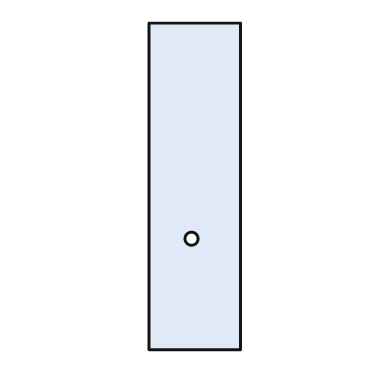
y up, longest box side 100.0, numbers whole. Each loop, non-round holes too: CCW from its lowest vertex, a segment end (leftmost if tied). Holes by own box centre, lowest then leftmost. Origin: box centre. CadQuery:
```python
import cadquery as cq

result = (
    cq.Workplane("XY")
    .moveTo(-14.0, -50.0)
    .lineTo(14.0, -50.0)
    .lineTo(14.0, 50.0)
    .lineTo(-14.0, 50.0)
    .close()
    .moveTo(-1.0, -16.0)
    .circle(2.0)
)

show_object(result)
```